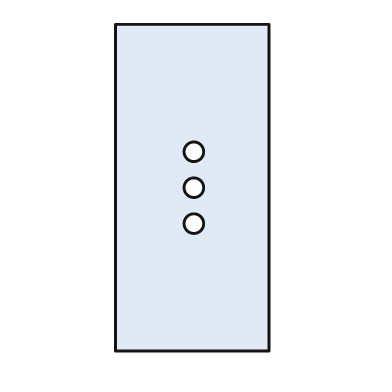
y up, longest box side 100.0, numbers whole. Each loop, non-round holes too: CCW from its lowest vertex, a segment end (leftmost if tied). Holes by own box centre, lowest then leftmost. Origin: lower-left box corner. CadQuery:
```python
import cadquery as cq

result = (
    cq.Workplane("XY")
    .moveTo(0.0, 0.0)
    .lineTo(47.0, 0.0)
    .lineTo(47.0, 100.0)
    .lineTo(0.0, 100.0)
    .close()
    .moveTo(24.0, 39.0)
    .circle(3.0)
    .moveTo(24.0, 50.0)
    .circle(3.0)
    .moveTo(24.0, 61.0)
    .circle(3.0)
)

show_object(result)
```